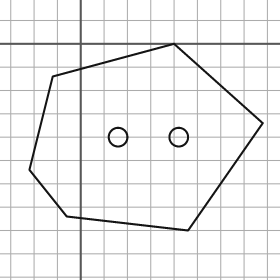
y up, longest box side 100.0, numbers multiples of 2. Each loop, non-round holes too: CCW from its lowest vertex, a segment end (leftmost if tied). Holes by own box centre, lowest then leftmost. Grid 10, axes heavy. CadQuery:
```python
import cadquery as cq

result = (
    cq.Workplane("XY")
    .moveTo(46.0, -80.0)
    .lineTo(78.0, -34.0)
    .lineTo(40.0, 0.0)
    .lineTo(-12.0, -14.0)
    .lineTo(-22.0, -54.0)
    .lineTo(-6.0, -74.0)
    .close()
    .moveTo(16.0, -40.0)
    .circle(4.0)
    .moveTo(42.0, -40.0)
    .circle(4.0)
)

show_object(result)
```